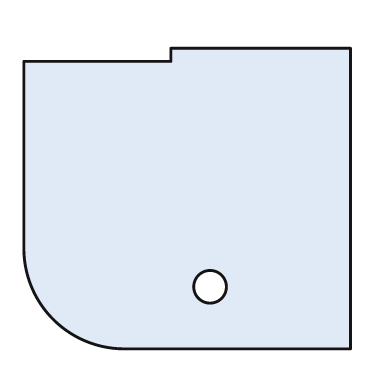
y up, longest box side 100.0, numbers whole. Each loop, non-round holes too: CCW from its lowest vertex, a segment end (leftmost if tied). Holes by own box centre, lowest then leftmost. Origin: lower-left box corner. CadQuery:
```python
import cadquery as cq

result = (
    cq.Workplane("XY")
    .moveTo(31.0, 0.0)
    .lineTo(100.0, 0.0)
    .lineTo(100.0, 92.0)
    .lineTo(45.0, 92.0)
    .lineTo(45.0, 88.0)
    .lineTo(0.0, 88.0)
    .lineTo(0.0, 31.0)
    .threePointArc((9.0, 9.0), (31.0, 0.0))
    .close()
    .moveTo(57.0, 19.0)
    .circle(5.0)
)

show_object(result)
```